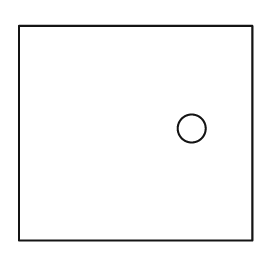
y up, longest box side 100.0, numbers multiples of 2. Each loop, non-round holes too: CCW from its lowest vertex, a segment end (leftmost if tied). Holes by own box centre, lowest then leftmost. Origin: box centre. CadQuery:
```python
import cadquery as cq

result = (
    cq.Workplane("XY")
    .moveTo(-50.0, -46.0)
    .lineTo(50.0, -46.0)
    .lineTo(50.0, 46.0)
    .lineTo(-50.0, 46.0)
    .close()
    .moveTo(24.0, 2.0)
    .circle(6.0)
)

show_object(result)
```